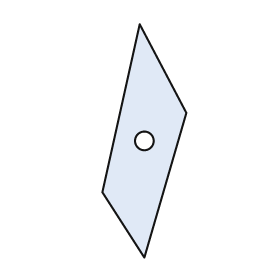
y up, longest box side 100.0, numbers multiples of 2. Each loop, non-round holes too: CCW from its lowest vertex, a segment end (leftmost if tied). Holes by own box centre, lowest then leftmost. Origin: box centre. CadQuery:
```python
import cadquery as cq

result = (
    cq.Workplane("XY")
    .moveTo(0.0, -50.0)
    .lineTo(18.0, 12.0)
    .lineTo(-2.0, 50.0)
    .lineTo(-18.0, -22.0)
    .close()
    .moveTo(0.0, 0.0)
    .circle(4.0)
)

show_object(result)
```